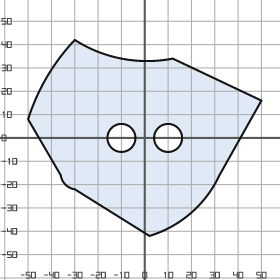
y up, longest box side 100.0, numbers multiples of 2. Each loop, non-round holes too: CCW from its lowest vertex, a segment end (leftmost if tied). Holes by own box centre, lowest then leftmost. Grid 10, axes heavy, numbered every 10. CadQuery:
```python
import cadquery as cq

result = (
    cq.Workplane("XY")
    .moveTo(2.0, -42.0)
    .threePointArc((20.0, -32.0), (32.0, -16.0))
    .lineTo(50.0, 16.0)
    .lineTo(12.0, 34.0)
    .threePointArc((-10.0, 34.0), (-30.0, 42.0))
    .threePointArc((-42.0, 26.0), (-50.0, 8.0))
    .lineTo(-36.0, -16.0)
    .threePointArc((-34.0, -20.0), (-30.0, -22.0))
    .close()
    .moveTo(-10.0, 0.0)
    .circle(6.0)
    .moveTo(10.0, 0.0)
    .circle(6.0)
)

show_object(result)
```